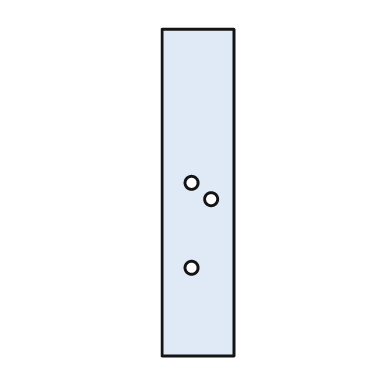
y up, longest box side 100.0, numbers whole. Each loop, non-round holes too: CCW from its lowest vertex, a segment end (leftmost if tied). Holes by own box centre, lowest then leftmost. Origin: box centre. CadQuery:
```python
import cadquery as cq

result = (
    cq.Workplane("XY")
    .moveTo(-11.0, -50.0)
    .lineTo(11.0, -50.0)
    .lineTo(11.0, 50.0)
    .lineTo(-11.0, 50.0)
    .close()
    .moveTo(-2.0, -23.0)
    .circle(2.0)
    .moveTo(4.0, -2.0)
    .circle(2.0)
    .moveTo(-2.0, 3.0)
    .circle(2.0)
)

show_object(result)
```